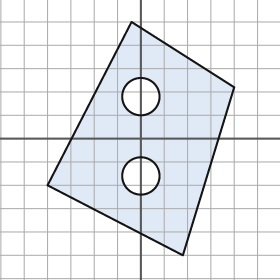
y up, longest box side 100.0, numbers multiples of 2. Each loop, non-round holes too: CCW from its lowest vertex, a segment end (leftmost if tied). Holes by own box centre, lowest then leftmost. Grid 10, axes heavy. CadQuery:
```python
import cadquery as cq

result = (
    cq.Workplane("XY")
    .moveTo(18.0, -50.0)
    .lineTo(40.0, 22.0)
    .lineTo(-4.0, 50.0)
    .lineTo(-40.0, -20.0)
    .close()
    .moveTo(0.0, -16.0)
    .circle(8.0)
    .moveTo(0.0, 18.0)
    .circle(8.0)
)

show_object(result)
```